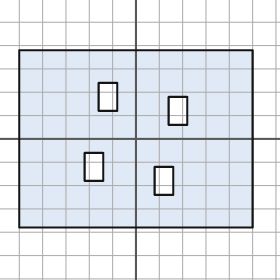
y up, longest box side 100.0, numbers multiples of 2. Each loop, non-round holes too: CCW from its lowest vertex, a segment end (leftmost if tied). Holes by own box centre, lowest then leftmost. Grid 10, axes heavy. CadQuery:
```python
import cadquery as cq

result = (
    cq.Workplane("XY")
    .moveTo(-50.0, -38.0)
    .lineTo(50.0, -38.0)
    .lineTo(50.0, 38.0)
    .lineTo(-50.0, 38.0)
    .close()
    .moveTo(8.0, -24.0)
    .lineTo(16.0, -24.0)
    .lineTo(16.0, -12.0)
    .lineTo(8.0, -12.0)
    .close()
    .moveTo(-22.0, -18.0)
    .lineTo(-14.0, -18.0)
    .lineTo(-14.0, -6.0)
    .lineTo(-22.0, -6.0)
    .close()
    .moveTo(14.0, 6.0)
    .lineTo(22.0, 6.0)
    .lineTo(22.0, 18.0)
    .lineTo(14.0, 18.0)
    .close()
    .moveTo(-16.0, 12.0)
    .lineTo(-8.0, 12.0)
    .lineTo(-8.0, 24.0)
    .lineTo(-16.0, 24.0)
    .close()
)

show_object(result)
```